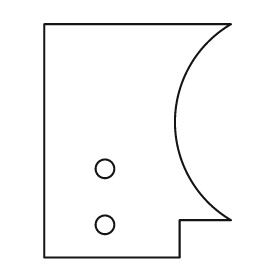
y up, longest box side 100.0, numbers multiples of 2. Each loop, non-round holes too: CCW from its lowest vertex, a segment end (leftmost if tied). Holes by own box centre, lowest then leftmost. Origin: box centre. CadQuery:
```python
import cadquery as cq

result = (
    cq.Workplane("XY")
    .moveTo(-40.0, -50.0)
    .lineTo(18.0, -50.0)
    .lineTo(18.0, -34.0)
    .lineTo(40.0, -34.0)
    .threePointArc((16.0, 8.0), (40.0, 50.0))
    .lineTo(-40.0, 50.0)
    .close()
    .moveTo(-14.0, -36.0)
    .circle(4.0)
    .moveTo(-14.0, -12.0)
    .circle(4.0)
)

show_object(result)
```